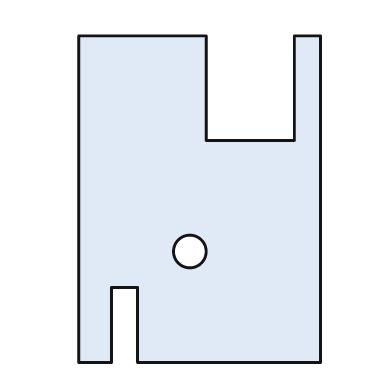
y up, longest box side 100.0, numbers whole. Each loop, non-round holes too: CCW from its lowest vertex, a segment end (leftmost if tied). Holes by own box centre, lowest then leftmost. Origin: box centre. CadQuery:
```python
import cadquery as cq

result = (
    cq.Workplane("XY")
    .moveTo(-37.0, -50.0)
    .lineTo(-27.0, -50.0)
    .lineTo(-27.0, -27.0)
    .lineTo(-19.0, -27.0)
    .lineTo(-19.0, -50.0)
    .lineTo(37.0, -50.0)
    .lineTo(37.0, 50.0)
    .lineTo(29.0, 50.0)
    .lineTo(29.0, 18.0)
    .lineTo(2.0, 18.0)
    .lineTo(2.0, 50.0)
    .lineTo(-37.0, 50.0)
    .close()
    .moveTo(-3.0, -16.0)
    .circle(5.0)
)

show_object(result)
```